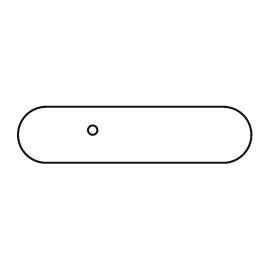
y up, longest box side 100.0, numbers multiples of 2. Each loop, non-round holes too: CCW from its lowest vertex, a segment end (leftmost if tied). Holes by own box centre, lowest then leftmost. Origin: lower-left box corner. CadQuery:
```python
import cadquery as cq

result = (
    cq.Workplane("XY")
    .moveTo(12.0, 0.0)
    .lineTo(88.0, 0.0)
    .threePointArc((100.0, 12.0), (88.0, 24.0))
    .lineTo(12.0, 24.0)
    .threePointArc((0.0, 12.0), (12.0, 0.0))
    .close()
    .moveTo(32.0, 14.0)
    .circle(2.0)
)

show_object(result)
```